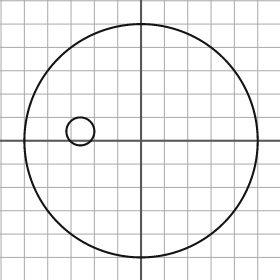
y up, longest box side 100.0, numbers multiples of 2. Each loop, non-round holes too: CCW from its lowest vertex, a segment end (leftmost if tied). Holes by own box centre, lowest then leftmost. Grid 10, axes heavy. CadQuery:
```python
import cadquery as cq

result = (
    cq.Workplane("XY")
    .moveTo(0.0, 0.0)
    .circle(50.0)
    .moveTo(-26.0, 4.0)
    .circle(6.0)
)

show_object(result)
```